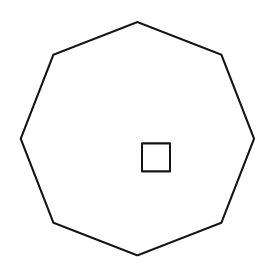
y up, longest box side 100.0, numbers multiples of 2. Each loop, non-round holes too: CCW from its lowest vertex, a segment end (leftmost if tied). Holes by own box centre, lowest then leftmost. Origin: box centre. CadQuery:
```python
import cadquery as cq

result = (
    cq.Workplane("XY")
    .moveTo(0.0, -50.0)
    .lineTo(36.0, -36.0)
    .lineTo(50.0, 0.0)
    .lineTo(36.0, 36.0)
    .lineTo(0.0, 50.0)
    .lineTo(-36.0, 36.0)
    .lineTo(-50.0, 0.0)
    .lineTo(-36.0, -36.0)
    .close()
    .moveTo(2.0, -14.0)
    .lineTo(14.0, -14.0)
    .lineTo(14.0, -2.0)
    .lineTo(2.0, -2.0)
    .close()
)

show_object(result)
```